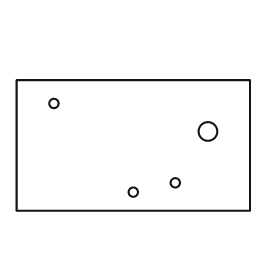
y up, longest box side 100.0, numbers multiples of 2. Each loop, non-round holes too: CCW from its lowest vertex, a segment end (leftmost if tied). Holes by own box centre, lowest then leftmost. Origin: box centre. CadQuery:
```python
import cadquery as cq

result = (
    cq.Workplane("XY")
    .moveTo(-50.0, -28.0)
    .lineTo(50.0, -28.0)
    .lineTo(50.0, 28.0)
    .lineTo(-50.0, 28.0)
    .close()
    .moveTo(0.0, -20.0)
    .circle(2.0)
    .moveTo(18.0, -16.0)
    .circle(2.0)
    .moveTo(32.0, 6.0)
    .circle(4.0)
    .moveTo(-34.0, 18.0)
    .circle(2.0)
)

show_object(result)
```